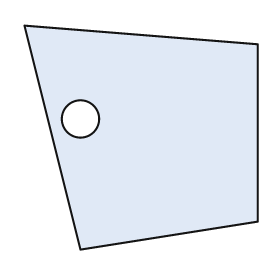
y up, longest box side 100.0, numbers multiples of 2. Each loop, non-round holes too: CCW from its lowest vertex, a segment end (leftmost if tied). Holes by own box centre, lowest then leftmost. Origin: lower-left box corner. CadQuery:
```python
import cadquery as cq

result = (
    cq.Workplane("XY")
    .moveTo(24.0, 0.0)
    .lineTo(100.0, 12.0)
    .lineTo(100.0, 88.0)
    .lineTo(0.0, 96.0)
    .close()
    .moveTo(24.0, 56.0)
    .circle(8.0)
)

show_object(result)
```